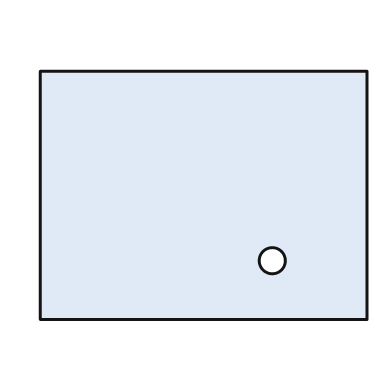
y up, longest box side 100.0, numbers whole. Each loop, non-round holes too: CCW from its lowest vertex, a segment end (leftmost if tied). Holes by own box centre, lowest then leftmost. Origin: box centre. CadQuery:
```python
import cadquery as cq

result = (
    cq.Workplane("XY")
    .moveTo(-50.0, -38.0)
    .lineTo(50.0, -38.0)
    .lineTo(50.0, 38.0)
    .lineTo(-50.0, 38.0)
    .close()
    .moveTo(21.0, -20.0)
    .circle(4.0)
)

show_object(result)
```